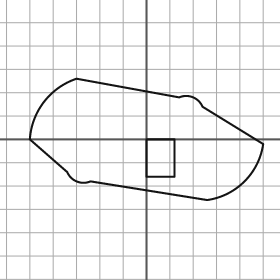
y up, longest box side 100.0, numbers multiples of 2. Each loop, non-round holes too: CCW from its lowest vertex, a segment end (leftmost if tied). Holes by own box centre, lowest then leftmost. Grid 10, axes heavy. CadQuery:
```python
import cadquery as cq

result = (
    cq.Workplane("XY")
    .moveTo(26.0, -26.0)
    .threePointArc((42.0, -18.0), (50.0, -2.0))
    .lineTo(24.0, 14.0)
    .threePointArc((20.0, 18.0), (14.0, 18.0))
    .lineTo(-30.0, 26.0)
    .threePointArc((-44.0, 16.0), (-50.0, 0.0))
    .lineTo(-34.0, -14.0)
    .threePointArc((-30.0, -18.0), (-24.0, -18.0))
    .close()
    .moveTo(0.0, -16.0)
    .lineTo(12.0, -16.0)
    .lineTo(12.0, 0.0)
    .lineTo(0.0, 0.0)
    .close()
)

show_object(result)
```